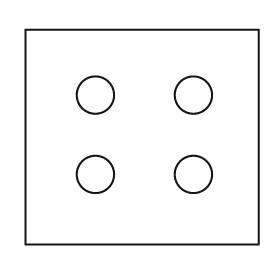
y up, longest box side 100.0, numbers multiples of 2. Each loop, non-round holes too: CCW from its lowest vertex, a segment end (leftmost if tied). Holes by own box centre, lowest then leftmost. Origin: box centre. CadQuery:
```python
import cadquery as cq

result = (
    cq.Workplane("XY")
    .moveTo(-50.0, -46.0)
    .lineTo(50.0, -46.0)
    .lineTo(50.0, 46.0)
    .lineTo(-50.0, 46.0)
    .close()
    .moveTo(-20.0, -16.0)
    .circle(8.0)
    .moveTo(22.0, -16.0)
    .circle(8.0)
    .moveTo(-20.0, 18.0)
    .circle(8.0)
    .moveTo(22.0, 18.0)
    .circle(8.0)
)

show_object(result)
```